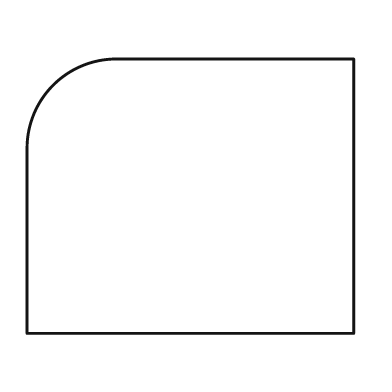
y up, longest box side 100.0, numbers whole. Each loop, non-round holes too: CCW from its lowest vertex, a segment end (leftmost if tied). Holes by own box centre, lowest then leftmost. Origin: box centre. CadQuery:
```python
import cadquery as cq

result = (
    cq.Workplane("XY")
    .moveTo(-50.0, -42.0)
    .lineTo(50.0, -42.0)
    .lineTo(50.0, 42.0)
    .lineTo(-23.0, 42.0)
    .threePointArc((-42.0, 34.0), (-50.0, 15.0))
    .close()
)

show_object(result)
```